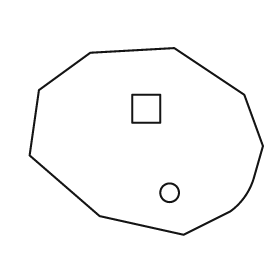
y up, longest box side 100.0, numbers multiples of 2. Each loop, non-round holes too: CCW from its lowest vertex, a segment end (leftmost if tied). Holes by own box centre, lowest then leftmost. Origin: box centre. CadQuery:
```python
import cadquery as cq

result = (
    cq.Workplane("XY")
    .moveTo(16.0, -40.0)
    .lineTo(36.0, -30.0)
    .threePointArc((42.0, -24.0), (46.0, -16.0))
    .lineTo(50.0, -2.0)
    .lineTo(42.0, 20.0)
    .lineTo(12.0, 40.0)
    .lineTo(-24.0, 38.0)
    .lineTo(-46.0, 22.0)
    .lineTo(-50.0, -6.0)
    .lineTo(-20.0, -32.0)
    .close()
    .moveTo(10.0, -22.0)
    .circle(4.0)
    .moveTo(-6.0, 8.0)
    .lineTo(6.0, 8.0)
    .lineTo(6.0, 20.0)
    .lineTo(-6.0, 20.0)
    .close()
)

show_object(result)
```